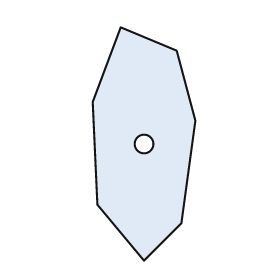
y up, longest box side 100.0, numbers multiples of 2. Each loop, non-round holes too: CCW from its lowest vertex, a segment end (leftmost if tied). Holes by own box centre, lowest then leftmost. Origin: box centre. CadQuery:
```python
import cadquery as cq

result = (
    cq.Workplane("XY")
    .moveTo(0.0, -50.0)
    .lineTo(16.0, -34.0)
    .lineTo(22.0, 10.0)
    .lineTo(14.0, 40.0)
    .lineTo(-10.0, 50.0)
    .lineTo(-22.0, 18.0)
    .lineTo(-20.0, -26.0)
    .close()
    .moveTo(0.0, 0.0)
    .circle(4.0)
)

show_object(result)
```